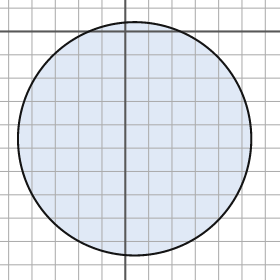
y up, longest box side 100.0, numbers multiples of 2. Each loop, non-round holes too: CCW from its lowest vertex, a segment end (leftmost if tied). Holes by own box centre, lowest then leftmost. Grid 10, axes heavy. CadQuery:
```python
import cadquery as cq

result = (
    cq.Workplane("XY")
    .moveTo(4.0, -46.0)
    .circle(50.0)
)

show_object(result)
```